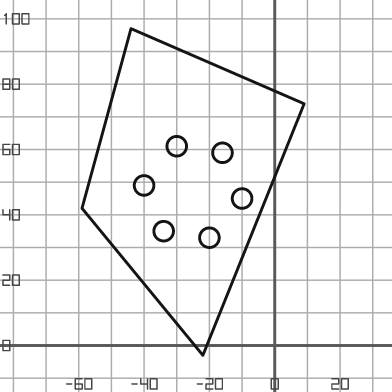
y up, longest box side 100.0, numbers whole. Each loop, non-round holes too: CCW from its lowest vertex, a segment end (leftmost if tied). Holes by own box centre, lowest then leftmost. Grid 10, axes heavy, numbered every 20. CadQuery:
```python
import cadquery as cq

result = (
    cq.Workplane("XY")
    .moveTo(-22.0, -3.0)
    .lineTo(9.0, 74.0)
    .lineTo(-44.0, 97.0)
    .lineTo(-59.0, 42.0)
    .close()
    .moveTo(-20.0, 33.0)
    .circle(3.0)
    .moveTo(-34.0, 35.0)
    .circle(3.0)
    .moveTo(-10.0, 45.0)
    .circle(3.0)
    .moveTo(-40.0, 49.0)
    .circle(3.0)
    .moveTo(-16.0, 59.0)
    .circle(3.0)
    .moveTo(-30.0, 61.0)
    .circle(3.0)
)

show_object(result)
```